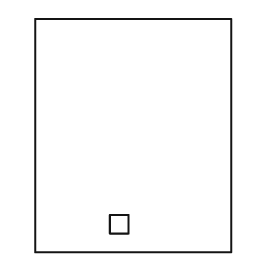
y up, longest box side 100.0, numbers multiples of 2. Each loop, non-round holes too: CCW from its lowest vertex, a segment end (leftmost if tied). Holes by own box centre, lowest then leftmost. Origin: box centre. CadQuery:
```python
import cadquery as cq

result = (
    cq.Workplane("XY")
    .moveTo(-42.0, -50.0)
    .lineTo(42.0, -50.0)
    .lineTo(42.0, 50.0)
    .lineTo(-42.0, 50.0)
    .close()
    .moveTo(-10.0, -42.0)
    .lineTo(-2.0, -42.0)
    .lineTo(-2.0, -34.0)
    .lineTo(-10.0, -34.0)
    .close()
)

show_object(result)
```